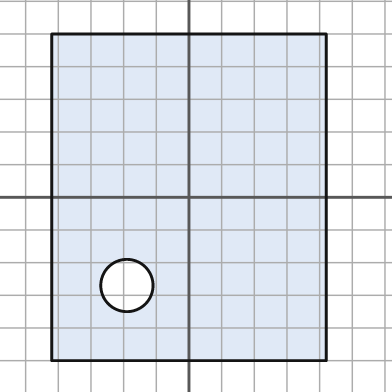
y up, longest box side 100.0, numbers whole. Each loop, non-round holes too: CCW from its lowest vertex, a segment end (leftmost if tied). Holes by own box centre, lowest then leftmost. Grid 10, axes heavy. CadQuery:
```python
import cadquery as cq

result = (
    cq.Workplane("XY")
    .moveTo(-42.0, -50.0)
    .lineTo(42.0, -50.0)
    .lineTo(42.0, 50.0)
    .lineTo(-42.0, 50.0)
    .close()
    .moveTo(-19.0, -27.0)
    .circle(8.0)
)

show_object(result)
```